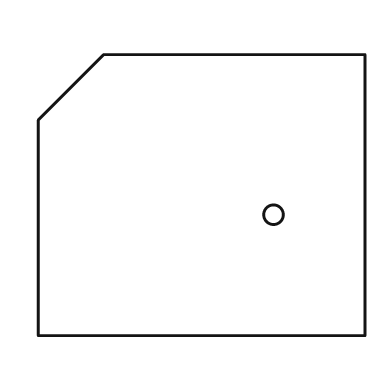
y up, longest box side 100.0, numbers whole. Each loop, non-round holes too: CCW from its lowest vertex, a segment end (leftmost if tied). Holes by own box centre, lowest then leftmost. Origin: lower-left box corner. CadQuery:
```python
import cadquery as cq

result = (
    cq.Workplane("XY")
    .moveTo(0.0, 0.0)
    .lineTo(100.0, 0.0)
    .lineTo(100.0, 86.0)
    .lineTo(20.0, 86.0)
    .lineTo(0.0, 66.0)
    .close()
    .moveTo(72.0, 37.0)
    .circle(3.0)
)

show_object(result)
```